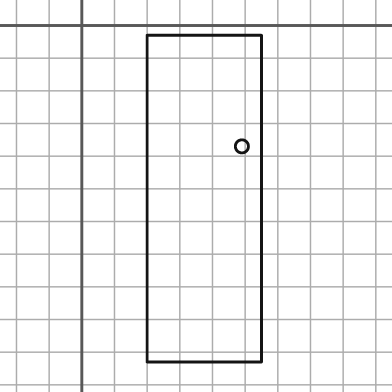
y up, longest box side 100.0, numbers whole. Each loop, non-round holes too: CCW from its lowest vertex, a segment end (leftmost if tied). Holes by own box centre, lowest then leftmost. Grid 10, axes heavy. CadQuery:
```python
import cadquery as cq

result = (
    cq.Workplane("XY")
    .moveTo(20.0, -103.0)
    .lineTo(55.0, -103.0)
    .lineTo(55.0, -3.0)
    .lineTo(20.0, -3.0)
    .close()
    .moveTo(49.0, -37.0)
    .circle(2.0)
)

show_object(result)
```